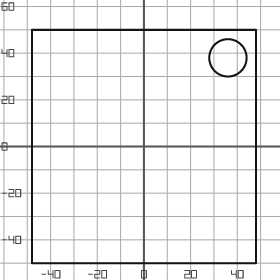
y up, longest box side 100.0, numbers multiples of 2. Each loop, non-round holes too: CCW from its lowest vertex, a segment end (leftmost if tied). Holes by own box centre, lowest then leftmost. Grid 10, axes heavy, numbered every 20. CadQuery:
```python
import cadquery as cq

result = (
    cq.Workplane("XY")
    .moveTo(-48.0, -50.0)
    .lineTo(48.0, -50.0)
    .lineTo(48.0, 50.0)
    .lineTo(-48.0, 50.0)
    .close()
    .moveTo(36.0, 38.0)
    .circle(8.0)
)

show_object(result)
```